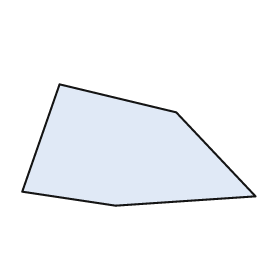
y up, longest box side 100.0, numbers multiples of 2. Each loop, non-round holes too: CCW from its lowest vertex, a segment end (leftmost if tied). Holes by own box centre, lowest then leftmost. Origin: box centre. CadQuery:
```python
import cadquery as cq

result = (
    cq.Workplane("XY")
    .moveTo(-10.0, -26.0)
    .lineTo(50.0, -22.0)
    .lineTo(16.0, 14.0)
    .lineTo(-34.0, 26.0)
    .lineTo(-50.0, -20.0)
    .close()
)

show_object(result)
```